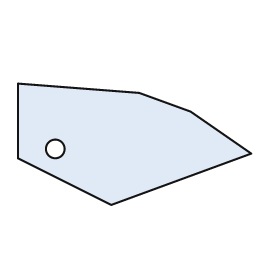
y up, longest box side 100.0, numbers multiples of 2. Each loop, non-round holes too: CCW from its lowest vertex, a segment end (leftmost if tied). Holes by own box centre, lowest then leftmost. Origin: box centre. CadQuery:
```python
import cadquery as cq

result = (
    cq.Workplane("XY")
    .moveTo(-10.0, -26.0)
    .lineTo(50.0, -4.0)
    .lineTo(24.0, 14.0)
    .lineTo(2.0, 22.0)
    .lineTo(-50.0, 26.0)
    .lineTo(-50.0, -6.0)
    .close()
    .moveTo(-34.0, -2.0)
    .circle(4.0)
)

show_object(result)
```